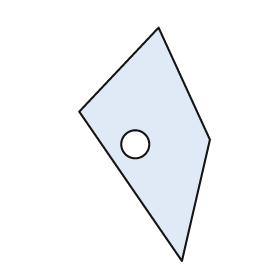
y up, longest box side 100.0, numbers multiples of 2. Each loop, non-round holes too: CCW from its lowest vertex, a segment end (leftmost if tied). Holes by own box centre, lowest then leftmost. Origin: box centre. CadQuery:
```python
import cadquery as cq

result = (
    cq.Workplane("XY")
    .moveTo(16.0, -50.0)
    .lineTo(28.0, 2.0)
    .lineTo(6.0, 50.0)
    .lineTo(-28.0, 14.0)
    .close()
    .moveTo(-4.0, 0.0)
    .circle(6.0)
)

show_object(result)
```